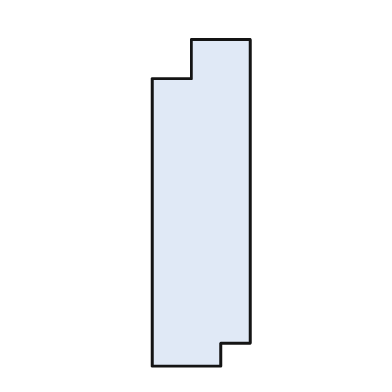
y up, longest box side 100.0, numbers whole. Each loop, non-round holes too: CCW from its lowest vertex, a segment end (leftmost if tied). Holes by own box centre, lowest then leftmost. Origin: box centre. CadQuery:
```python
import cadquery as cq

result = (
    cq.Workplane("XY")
    .moveTo(-15.0, -50.0)
    .lineTo(6.0, -50.0)
    .lineTo(6.0, -43.0)
    .lineTo(15.0, -43.0)
    .lineTo(15.0, 50.0)
    .lineTo(-3.0, 50.0)
    .lineTo(-3.0, 38.0)
    .lineTo(-15.0, 38.0)
    .close()
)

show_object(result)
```